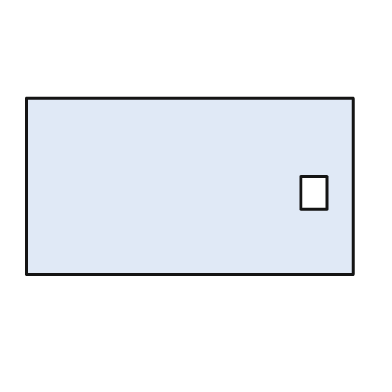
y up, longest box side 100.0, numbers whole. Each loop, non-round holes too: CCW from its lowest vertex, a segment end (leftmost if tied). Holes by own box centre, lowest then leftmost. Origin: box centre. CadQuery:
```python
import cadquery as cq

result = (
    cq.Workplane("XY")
    .moveTo(-50.0, -27.0)
    .lineTo(50.0, -27.0)
    .lineTo(50.0, 27.0)
    .lineTo(-50.0, 27.0)
    .close()
    .moveTo(34.0, -7.0)
    .lineTo(42.0, -7.0)
    .lineTo(42.0, 3.0)
    .lineTo(34.0, 3.0)
    .close()
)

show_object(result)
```